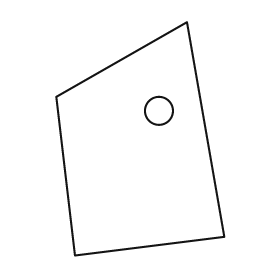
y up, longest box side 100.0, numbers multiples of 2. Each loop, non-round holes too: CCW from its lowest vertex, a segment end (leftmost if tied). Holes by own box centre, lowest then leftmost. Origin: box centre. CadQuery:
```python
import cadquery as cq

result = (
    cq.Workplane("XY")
    .moveTo(-28.0, -50.0)
    .lineTo(36.0, -42.0)
    .lineTo(20.0, 50.0)
    .lineTo(-36.0, 18.0)
    .close()
    .moveTo(8.0, 12.0)
    .circle(6.0)
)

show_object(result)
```